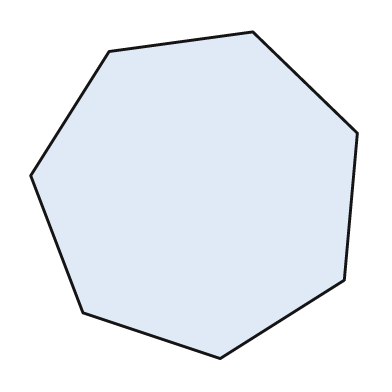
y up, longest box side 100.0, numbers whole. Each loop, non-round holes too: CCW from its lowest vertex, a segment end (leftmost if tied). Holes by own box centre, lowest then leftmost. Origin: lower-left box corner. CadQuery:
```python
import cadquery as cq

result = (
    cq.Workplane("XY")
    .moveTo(58.0, 0.0)
    .lineTo(96.0, 24.0)
    .lineTo(100.0, 69.0)
    .lineTo(68.0, 100.0)
    .lineTo(24.0, 94.0)
    .lineTo(0.0, 56.0)
    .lineTo(16.0, 14.0)
    .close()
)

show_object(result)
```